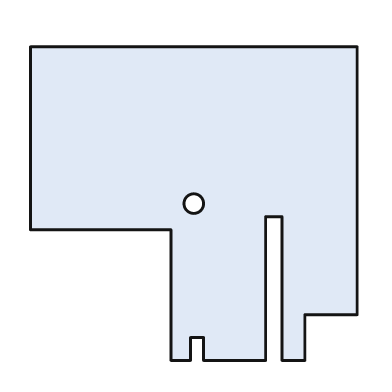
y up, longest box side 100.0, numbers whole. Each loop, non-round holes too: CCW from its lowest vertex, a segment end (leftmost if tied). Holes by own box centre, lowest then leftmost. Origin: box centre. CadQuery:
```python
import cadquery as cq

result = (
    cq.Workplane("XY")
    .moveTo(-7.0, -48.0)
    .lineTo(-1.0, -48.0)
    .lineTo(-1.0, -41.0)
    .lineTo(3.0, -41.0)
    .lineTo(3.0, -48.0)
    .lineTo(22.0, -48.0)
    .lineTo(22.0, -4.0)
    .lineTo(27.0, -4.0)
    .lineTo(27.0, -48.0)
    .lineTo(34.0, -48.0)
    .lineTo(34.0, -34.0)
    .lineTo(50.0, -34.0)
    .lineTo(50.0, 48.0)
    .lineTo(-50.0, 48.0)
    .lineTo(-50.0, -8.0)
    .lineTo(-7.0, -8.0)
    .close()
    .moveTo(0.0, 0.0)
    .circle(3.0)
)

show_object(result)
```